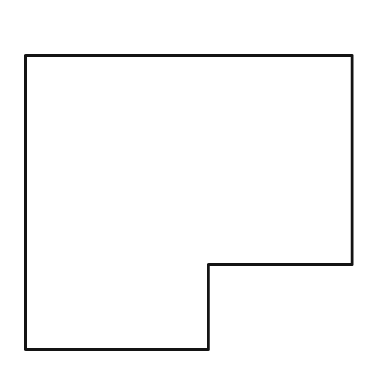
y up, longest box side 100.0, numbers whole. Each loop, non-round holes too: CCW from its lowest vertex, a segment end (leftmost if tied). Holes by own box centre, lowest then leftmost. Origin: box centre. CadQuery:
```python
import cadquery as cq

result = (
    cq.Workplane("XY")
    .moveTo(-50.0, -45.0)
    .lineTo(6.0, -45.0)
    .lineTo(6.0, -19.0)
    .lineTo(50.0, -19.0)
    .lineTo(50.0, 45.0)
    .lineTo(-50.0, 45.0)
    .close()
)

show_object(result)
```